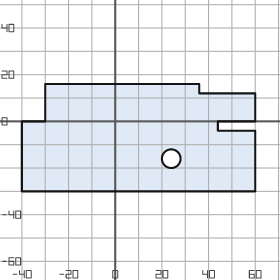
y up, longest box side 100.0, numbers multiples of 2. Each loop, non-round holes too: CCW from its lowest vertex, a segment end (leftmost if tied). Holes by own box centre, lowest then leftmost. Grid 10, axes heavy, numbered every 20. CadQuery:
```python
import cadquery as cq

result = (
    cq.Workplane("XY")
    .moveTo(-40.0, -30.0)
    .lineTo(60.0, -30.0)
    .lineTo(60.0, -4.0)
    .lineTo(44.0, -4.0)
    .lineTo(44.0, 0.0)
    .lineTo(60.0, 0.0)
    .lineTo(60.0, 12.0)
    .lineTo(36.0, 12.0)
    .lineTo(36.0, 16.0)
    .lineTo(-30.0, 16.0)
    .lineTo(-30.0, 0.0)
    .lineTo(-40.0, 0.0)
    .close()
    .moveTo(24.0, -16.0)
    .circle(4.0)
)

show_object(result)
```